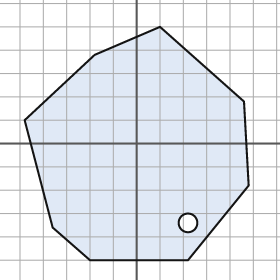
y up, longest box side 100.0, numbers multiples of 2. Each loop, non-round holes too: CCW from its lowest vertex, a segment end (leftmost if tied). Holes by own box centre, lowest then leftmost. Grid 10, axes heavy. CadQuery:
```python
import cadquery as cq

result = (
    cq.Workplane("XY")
    .moveTo(-20.0, -50.0)
    .lineTo(22.0, -50.0)
    .lineTo(48.0, -18.0)
    .lineTo(46.0, 18.0)
    .lineTo(10.0, 50.0)
    .lineTo(-18.0, 38.0)
    .lineTo(-48.0, 10.0)
    .lineTo(-36.0, -36.0)
    .close()
    .moveTo(22.0, -34.0)
    .circle(4.0)
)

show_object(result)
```